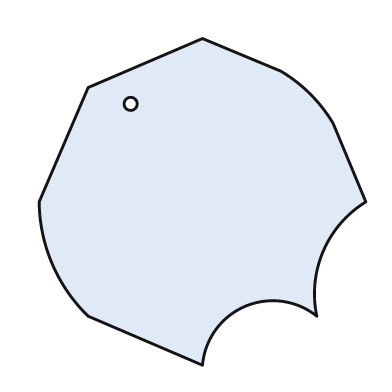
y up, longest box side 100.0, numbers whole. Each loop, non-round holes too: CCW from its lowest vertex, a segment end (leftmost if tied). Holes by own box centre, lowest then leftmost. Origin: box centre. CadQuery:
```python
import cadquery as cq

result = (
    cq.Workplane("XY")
    .moveTo(0.0, -50.0)
    .threePointArc((13.0, -32.0), (35.0, -35.0))
    .threePointArc((37.0, -15.0), (50.0, 0.0))
    .lineTo(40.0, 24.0)
    .threePointArc((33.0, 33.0), (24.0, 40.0))
    .lineTo(0.0, 50.0)
    .lineTo(-35.0, 35.0)
    .lineTo(-50.0, 0.0)
    .threePointArc((-46.0, -19.0), (-35.0, -35.0))
    .close()
    .moveTo(-22.0, 30.0)
    .circle(2.0)
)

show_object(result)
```